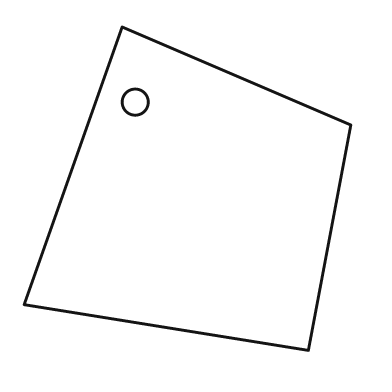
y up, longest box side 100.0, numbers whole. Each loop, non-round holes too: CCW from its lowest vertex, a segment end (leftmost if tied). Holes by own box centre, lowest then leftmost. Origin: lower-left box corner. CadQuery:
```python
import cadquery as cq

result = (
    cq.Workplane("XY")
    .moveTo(87.0, 0.0)
    .lineTo(100.0, 69.0)
    .lineTo(30.0, 99.0)
    .lineTo(0.0, 14.0)
    .close()
    .moveTo(34.0, 76.0)
    .circle(4.0)
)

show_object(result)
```